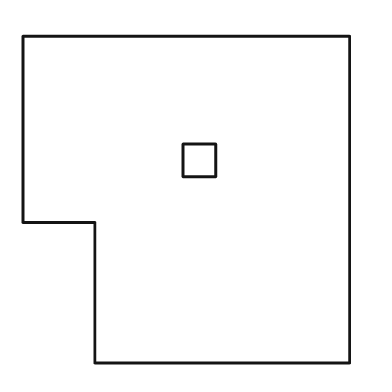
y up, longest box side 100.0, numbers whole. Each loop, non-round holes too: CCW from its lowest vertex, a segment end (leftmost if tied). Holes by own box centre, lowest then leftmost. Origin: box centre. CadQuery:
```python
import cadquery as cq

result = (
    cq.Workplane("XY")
    .moveTo(-28.0, -50.0)
    .lineTo(50.0, -50.0)
    .lineTo(50.0, 50.0)
    .lineTo(-50.0, 50.0)
    .lineTo(-50.0, -7.0)
    .lineTo(-28.0, -7.0)
    .close()
    .moveTo(-1.0, 7.0)
    .lineTo(9.0, 7.0)
    .lineTo(9.0, 17.0)
    .lineTo(-1.0, 17.0)
    .close()
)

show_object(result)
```